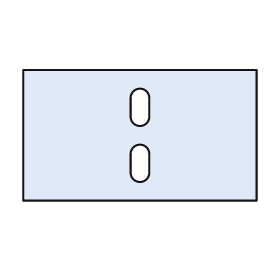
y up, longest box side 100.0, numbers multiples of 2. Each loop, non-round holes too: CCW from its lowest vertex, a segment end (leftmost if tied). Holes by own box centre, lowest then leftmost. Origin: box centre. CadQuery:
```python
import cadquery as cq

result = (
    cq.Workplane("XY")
    .moveTo(-50.0, -28.0)
    .lineTo(50.0, -28.0)
    .lineTo(50.0, 28.0)
    .lineTo(-50.0, 28.0)
    .close()
    .moveTo(-4.0, -16.0)
    .threePointArc((0.0, -20.0), (4.0, -16.0))
    .lineTo(4.0, -8.0)
    .threePointArc((0.0, -4.0), (-4.0, -8.0))
    .close()
    .moveTo(-4.0, 8.0)
    .threePointArc((0.0, 4.0), (4.0, 8.0))
    .lineTo(4.0, 16.0)
    .threePointArc((0.0, 20.0), (-4.0, 16.0))
    .close()
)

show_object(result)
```